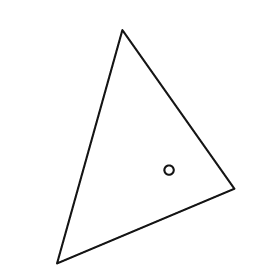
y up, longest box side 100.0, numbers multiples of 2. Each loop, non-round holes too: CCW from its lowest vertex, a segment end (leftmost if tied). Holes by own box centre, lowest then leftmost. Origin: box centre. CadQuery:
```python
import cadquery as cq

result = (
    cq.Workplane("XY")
    .moveTo(-38.0, -50.0)
    .lineTo(38.0, -18.0)
    .lineTo(-10.0, 50.0)
    .close()
    .moveTo(10.0, -10.0)
    .circle(2.0)
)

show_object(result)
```